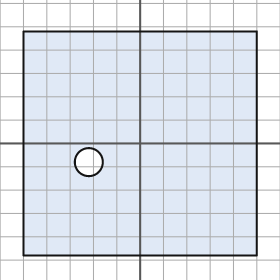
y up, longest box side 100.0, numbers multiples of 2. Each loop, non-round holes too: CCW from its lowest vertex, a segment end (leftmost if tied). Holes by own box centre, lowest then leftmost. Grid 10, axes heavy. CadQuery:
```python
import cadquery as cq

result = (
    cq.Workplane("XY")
    .moveTo(-50.0, -48.0)
    .lineTo(50.0, -48.0)
    .lineTo(50.0, 48.0)
    .lineTo(-50.0, 48.0)
    .close()
    .moveTo(-22.0, -8.0)
    .circle(6.0)
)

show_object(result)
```